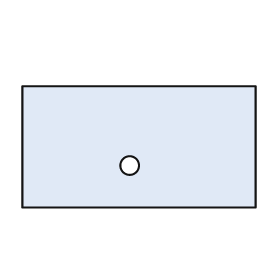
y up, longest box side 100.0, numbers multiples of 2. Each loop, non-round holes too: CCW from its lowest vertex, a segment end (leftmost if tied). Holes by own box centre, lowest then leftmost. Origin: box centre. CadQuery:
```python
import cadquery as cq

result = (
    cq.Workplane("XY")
    .moveTo(-50.0, -26.0)
    .lineTo(50.0, -26.0)
    .lineTo(50.0, 26.0)
    .lineTo(-50.0, 26.0)
    .close()
    .moveTo(-4.0, -8.0)
    .circle(4.0)
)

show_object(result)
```